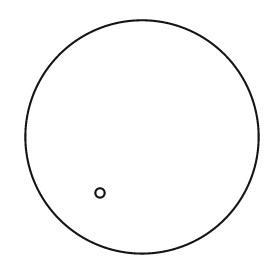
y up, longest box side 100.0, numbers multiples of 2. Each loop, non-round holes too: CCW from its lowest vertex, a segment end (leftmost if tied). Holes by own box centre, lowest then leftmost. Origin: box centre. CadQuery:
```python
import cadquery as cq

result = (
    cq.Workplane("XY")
    .moveTo(0.0, 0.0)
    .circle(50.0)
    .moveTo(-18.0, -24.0)
    .circle(2.0)
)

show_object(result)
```